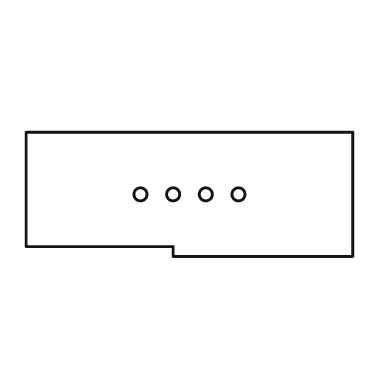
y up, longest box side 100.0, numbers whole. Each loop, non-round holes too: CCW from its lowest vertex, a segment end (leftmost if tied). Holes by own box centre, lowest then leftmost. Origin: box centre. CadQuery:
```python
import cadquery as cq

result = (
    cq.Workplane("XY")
    .moveTo(-5.0, -19.0)
    .lineTo(50.0, -19.0)
    .lineTo(50.0, 19.0)
    .lineTo(-50.0, 19.0)
    .lineTo(-50.0, -16.0)
    .lineTo(-5.0, -16.0)
    .close()
    .moveTo(-15.0, 0.0)
    .circle(2.0)
    .moveTo(-5.0, 0.0)
    .circle(2.0)
    .moveTo(5.0, 0.0)
    .circle(2.0)
    .moveTo(15.0, 0.0)
    .circle(2.0)
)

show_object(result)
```